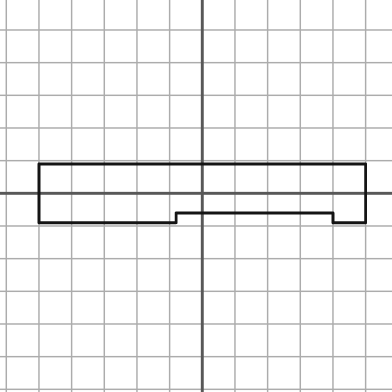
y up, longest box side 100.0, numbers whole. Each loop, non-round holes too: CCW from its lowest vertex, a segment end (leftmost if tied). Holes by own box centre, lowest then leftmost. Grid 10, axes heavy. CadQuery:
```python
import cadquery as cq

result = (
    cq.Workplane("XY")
    .moveTo(-50.0, -9.0)
    .lineTo(-8.0, -9.0)
    .lineTo(-8.0, -6.0)
    .lineTo(40.0, -6.0)
    .lineTo(40.0, -9.0)
    .lineTo(50.0, -9.0)
    .lineTo(50.0, 9.0)
    .lineTo(-50.0, 9.0)
    .close()
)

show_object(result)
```